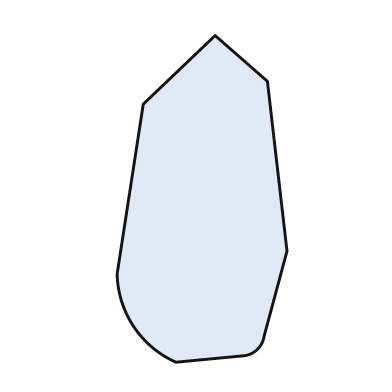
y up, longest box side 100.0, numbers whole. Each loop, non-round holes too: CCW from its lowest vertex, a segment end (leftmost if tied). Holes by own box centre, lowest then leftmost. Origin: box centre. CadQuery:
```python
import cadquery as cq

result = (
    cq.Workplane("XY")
    .moveTo(-8.0, -50.0)
    .lineTo(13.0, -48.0)
    .threePointArc((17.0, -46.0), (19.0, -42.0))
    .lineTo(26.0, -16.0)
    .lineTo(20.0, 36.0)
    .lineTo(4.0, 50.0)
    .lineTo(-18.0, 29.0)
    .lineTo(-26.0, -23.0)
    .threePointArc((-21.0, -39.0), (-8.0, -50.0))
    .close()
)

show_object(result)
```